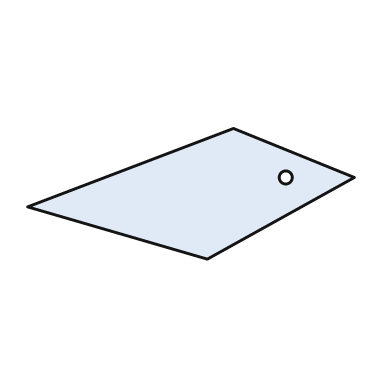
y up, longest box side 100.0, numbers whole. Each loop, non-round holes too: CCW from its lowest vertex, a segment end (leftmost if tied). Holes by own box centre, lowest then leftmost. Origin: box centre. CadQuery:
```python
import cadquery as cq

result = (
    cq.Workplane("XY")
    .moveTo(5.0, -20.0)
    .lineTo(50.0, 5.0)
    .lineTo(13.0, 20.0)
    .lineTo(-50.0, -4.0)
    .close()
    .moveTo(29.0, 5.0)
    .circle(2.0)
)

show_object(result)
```